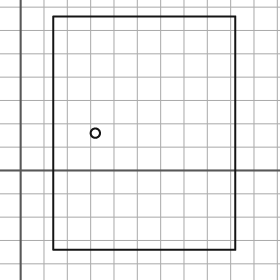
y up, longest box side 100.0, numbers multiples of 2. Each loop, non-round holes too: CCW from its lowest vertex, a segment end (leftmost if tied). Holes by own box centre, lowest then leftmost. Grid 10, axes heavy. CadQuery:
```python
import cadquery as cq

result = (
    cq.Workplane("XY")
    .moveTo(14.0, -34.0)
    .lineTo(92.0, -34.0)
    .lineTo(92.0, 66.0)
    .lineTo(14.0, 66.0)
    .close()
    .moveTo(32.0, 16.0)
    .circle(2.0)
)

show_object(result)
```